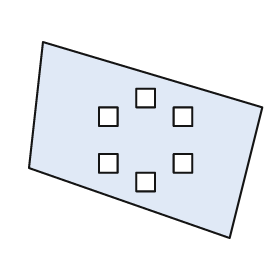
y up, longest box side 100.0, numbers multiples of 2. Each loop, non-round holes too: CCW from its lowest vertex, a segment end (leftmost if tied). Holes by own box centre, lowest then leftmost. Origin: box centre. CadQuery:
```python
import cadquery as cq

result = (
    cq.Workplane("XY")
    .moveTo(36.0, -42.0)
    .lineTo(50.0, 14.0)
    .lineTo(-44.0, 42.0)
    .lineTo(-50.0, -12.0)
    .close()
    .moveTo(-4.0, -22.0)
    .lineTo(4.0, -22.0)
    .lineTo(4.0, -14.0)
    .lineTo(-4.0, -14.0)
    .close()
    .moveTo(-20.0, -14.0)
    .lineTo(-12.0, -14.0)
    .lineTo(-12.0, -6.0)
    .lineTo(-20.0, -6.0)
    .close()
    .moveTo(12.0, -14.0)
    .lineTo(20.0, -14.0)
    .lineTo(20.0, -6.0)
    .lineTo(12.0, -6.0)
    .close()
    .moveTo(-20.0, 6.0)
    .lineTo(-12.0, 6.0)
    .lineTo(-12.0, 14.0)
    .lineTo(-20.0, 14.0)
    .close()
    .moveTo(12.0, 6.0)
    .lineTo(20.0, 6.0)
    .lineTo(20.0, 14.0)
    .lineTo(12.0, 14.0)
    .close()
    .moveTo(-4.0, 14.0)
    .lineTo(4.0, 14.0)
    .lineTo(4.0, 22.0)
    .lineTo(-4.0, 22.0)
    .close()
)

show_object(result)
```